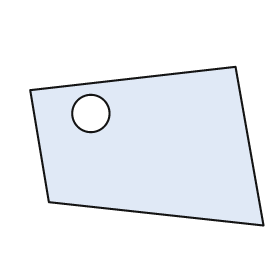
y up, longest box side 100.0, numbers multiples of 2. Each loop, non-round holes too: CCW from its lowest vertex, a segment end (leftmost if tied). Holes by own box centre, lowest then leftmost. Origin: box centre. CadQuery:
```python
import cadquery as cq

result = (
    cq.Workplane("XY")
    .moveTo(50.0, -34.0)
    .lineTo(38.0, 34.0)
    .lineTo(-50.0, 24.0)
    .lineTo(-42.0, -24.0)
    .close()
    .moveTo(-24.0, 14.0)
    .circle(8.0)
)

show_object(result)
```